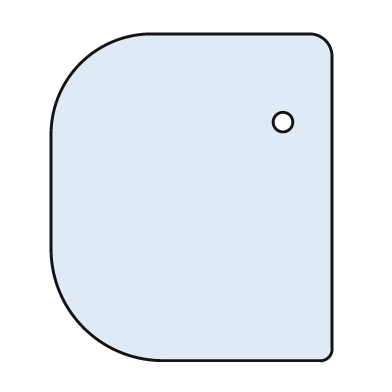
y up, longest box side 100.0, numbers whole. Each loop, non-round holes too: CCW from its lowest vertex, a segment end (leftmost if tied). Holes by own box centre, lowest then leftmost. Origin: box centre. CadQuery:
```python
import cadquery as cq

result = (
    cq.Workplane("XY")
    .moveTo(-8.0, -50.0)
    .lineTo(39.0, -50.0)
    .threePointArc((42.0, -49.0), (43.0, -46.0))
    .lineTo(43.0, 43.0)
    .threePointArc((41.0, 48.0), (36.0, 50.0))
    .lineTo(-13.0, 50.0)
    .threePointArc((-34.0, 41.0), (-43.0, 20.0))
    .lineTo(-43.0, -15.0)
    .threePointArc((-33.0, -40.0), (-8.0, -50.0))
    .close()
    .moveTo(28.0, 23.0)
    .circle(3.0)
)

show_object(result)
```